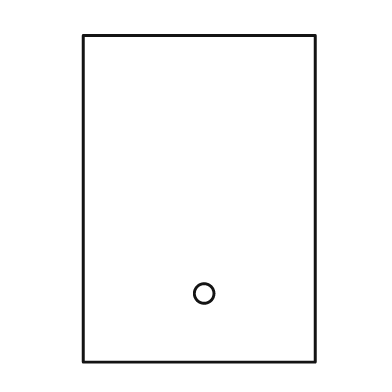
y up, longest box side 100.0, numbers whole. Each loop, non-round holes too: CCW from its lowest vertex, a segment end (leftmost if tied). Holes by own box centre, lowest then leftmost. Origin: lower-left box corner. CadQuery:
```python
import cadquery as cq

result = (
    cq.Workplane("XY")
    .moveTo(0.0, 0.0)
    .lineTo(71.0, 0.0)
    .lineTo(71.0, 100.0)
    .lineTo(0.0, 100.0)
    .close()
    .moveTo(37.0, 21.0)
    .circle(3.0)
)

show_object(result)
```